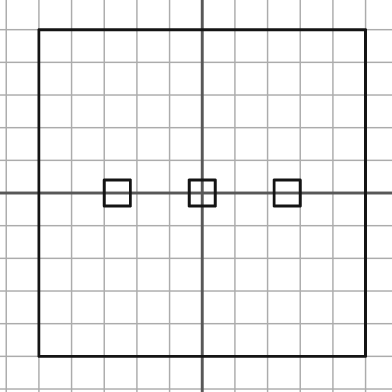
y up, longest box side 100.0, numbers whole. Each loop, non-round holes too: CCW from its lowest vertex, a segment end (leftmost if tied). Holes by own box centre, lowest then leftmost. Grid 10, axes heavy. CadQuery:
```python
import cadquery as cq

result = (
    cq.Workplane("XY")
    .moveTo(-50.0, -50.0)
    .lineTo(50.0, -50.0)
    .lineTo(50.0, 50.0)
    .lineTo(-50.0, 50.0)
    .close()
    .moveTo(-30.0, -4.0)
    .lineTo(-22.0, -4.0)
    .lineTo(-22.0, 4.0)
    .lineTo(-30.0, 4.0)
    .close()
    .moveTo(-4.0, -4.0)
    .lineTo(4.0, -4.0)
    .lineTo(4.0, 4.0)
    .lineTo(-4.0, 4.0)
    .close()
    .moveTo(22.0, -4.0)
    .lineTo(30.0, -4.0)
    .lineTo(30.0, 4.0)
    .lineTo(22.0, 4.0)
    .close()
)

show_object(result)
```